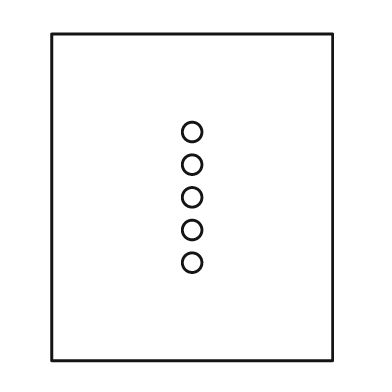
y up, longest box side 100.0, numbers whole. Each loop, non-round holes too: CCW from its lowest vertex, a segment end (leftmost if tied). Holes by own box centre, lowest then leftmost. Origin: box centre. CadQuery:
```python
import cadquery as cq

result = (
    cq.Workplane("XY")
    .moveTo(-43.0, -50.0)
    .lineTo(43.0, -50.0)
    .lineTo(43.0, 50.0)
    .lineTo(-43.0, 50.0)
    .close()
    .moveTo(0.0, -20.0)
    .circle(3.0)
    .moveTo(0.0, -10.0)
    .circle(3.0)
    .moveTo(0.0, 0.0)
    .circle(3.0)
    .moveTo(0.0, 10.0)
    .circle(3.0)
    .moveTo(0.0, 20.0)
    .circle(3.0)
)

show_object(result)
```